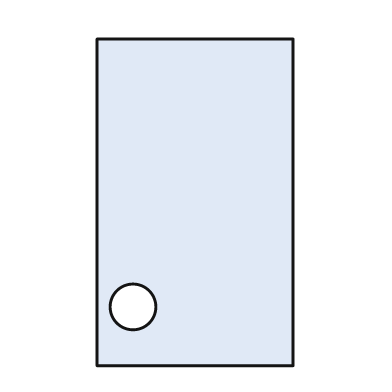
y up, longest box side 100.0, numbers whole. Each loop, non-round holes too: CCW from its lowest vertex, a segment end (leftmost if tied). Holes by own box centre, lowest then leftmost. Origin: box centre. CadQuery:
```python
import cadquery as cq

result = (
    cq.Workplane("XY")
    .moveTo(-30.0, -50.0)
    .lineTo(30.0, -50.0)
    .lineTo(30.0, 50.0)
    .lineTo(-30.0, 50.0)
    .close()
    .moveTo(-19.0, -32.0)
    .circle(7.0)
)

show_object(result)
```